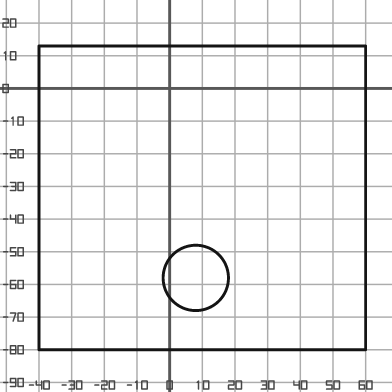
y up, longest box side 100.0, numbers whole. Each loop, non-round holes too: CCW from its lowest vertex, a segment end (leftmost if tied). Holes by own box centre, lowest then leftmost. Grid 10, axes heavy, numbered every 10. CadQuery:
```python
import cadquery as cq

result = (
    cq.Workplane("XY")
    .moveTo(-40.0, -80.0)
    .lineTo(60.0, -80.0)
    .lineTo(60.0, 13.0)
    .lineTo(-40.0, 13.0)
    .close()
    .moveTo(8.0, -58.0)
    .circle(10.0)
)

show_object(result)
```